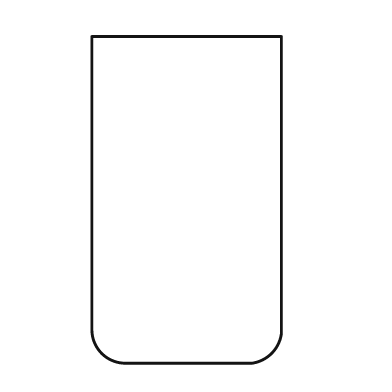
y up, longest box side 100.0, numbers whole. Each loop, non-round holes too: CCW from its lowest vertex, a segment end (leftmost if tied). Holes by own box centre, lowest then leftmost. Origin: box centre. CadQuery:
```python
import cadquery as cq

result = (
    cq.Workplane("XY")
    .moveTo(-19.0, -50.0)
    .lineTo(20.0, -50.0)
    .threePointArc((26.0, -47.0), (29.0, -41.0))
    .lineTo(29.0, 50.0)
    .lineTo(-29.0, 50.0)
    .lineTo(-29.0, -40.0)
    .threePointArc((-26.0, -47.0), (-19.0, -50.0))
    .close()
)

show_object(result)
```